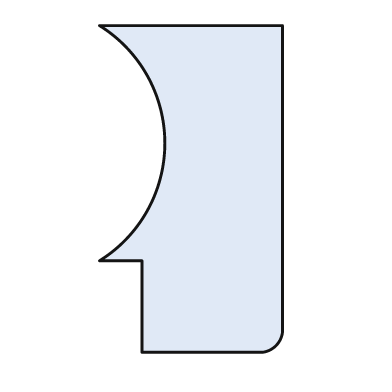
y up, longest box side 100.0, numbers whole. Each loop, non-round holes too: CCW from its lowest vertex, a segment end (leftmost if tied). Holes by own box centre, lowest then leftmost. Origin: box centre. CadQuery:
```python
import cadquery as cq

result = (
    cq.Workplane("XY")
    .moveTo(-15.0, -50.0)
    .lineTo(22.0, -50.0)
    .threePointArc((26.0, -48.0), (28.0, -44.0))
    .lineTo(28.0, 50.0)
    .lineTo(-28.0, 50.0)
    .threePointArc((-8.0, 14.0), (-28.0, -22.0))
    .lineTo(-15.0, -22.0)
    .close()
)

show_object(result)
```